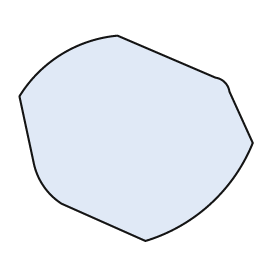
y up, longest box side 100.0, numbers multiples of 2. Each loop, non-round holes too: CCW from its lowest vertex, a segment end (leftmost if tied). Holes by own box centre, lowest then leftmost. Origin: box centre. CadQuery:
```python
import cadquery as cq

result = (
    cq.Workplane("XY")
    .moveTo(4.0, -44.0)
    .threePointArc((32.0, -28.0), (50.0, -2.0))
    .lineTo(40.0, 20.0)
    .threePointArc((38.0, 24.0), (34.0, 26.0))
    .lineTo(-8.0, 44.0)
    .threePointArc((-32.0, 36.0), (-50.0, 18.0))
    .lineTo(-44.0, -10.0)
    .threePointArc((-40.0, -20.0), (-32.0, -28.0))
    .close()
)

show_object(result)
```